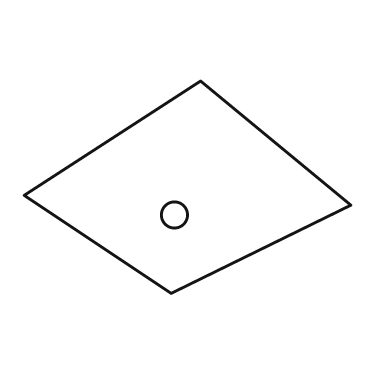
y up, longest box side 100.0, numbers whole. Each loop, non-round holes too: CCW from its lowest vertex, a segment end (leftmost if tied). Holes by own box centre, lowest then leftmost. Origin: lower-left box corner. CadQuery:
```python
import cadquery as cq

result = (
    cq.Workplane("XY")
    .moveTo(45.0, 0.0)
    .lineTo(100.0, 27.0)
    .lineTo(54.0, 65.0)
    .lineTo(0.0, 30.0)
    .close()
    .moveTo(46.0, 24.0)
    .circle(4.0)
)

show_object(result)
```